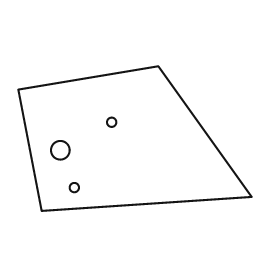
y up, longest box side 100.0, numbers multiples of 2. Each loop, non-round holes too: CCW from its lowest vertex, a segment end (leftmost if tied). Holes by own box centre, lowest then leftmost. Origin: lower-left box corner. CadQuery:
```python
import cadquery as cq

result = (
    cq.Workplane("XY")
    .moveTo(10.0, 0.0)
    .lineTo(100.0, 6.0)
    .lineTo(60.0, 62.0)
    .lineTo(0.0, 52.0)
    .close()
    .moveTo(24.0, 10.0)
    .circle(2.0)
    .moveTo(18.0, 26.0)
    .circle(4.0)
    .moveTo(40.0, 38.0)
    .circle(2.0)
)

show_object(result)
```